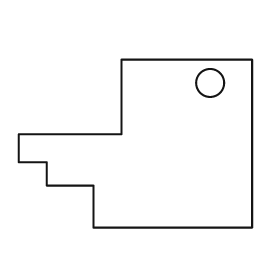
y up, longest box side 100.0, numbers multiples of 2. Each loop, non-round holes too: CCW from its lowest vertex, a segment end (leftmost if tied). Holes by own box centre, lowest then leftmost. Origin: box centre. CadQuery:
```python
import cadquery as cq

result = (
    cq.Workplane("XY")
    .moveTo(-18.0, -36.0)
    .lineTo(50.0, -36.0)
    .lineTo(50.0, 36.0)
    .lineTo(-6.0, 36.0)
    .lineTo(-6.0, 4.0)
    .lineTo(-50.0, 4.0)
    .lineTo(-50.0, -8.0)
    .lineTo(-38.0, -8.0)
    .lineTo(-38.0, -18.0)
    .lineTo(-18.0, -18.0)
    .close()
    .moveTo(32.0, 26.0)
    .circle(6.0)
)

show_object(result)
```